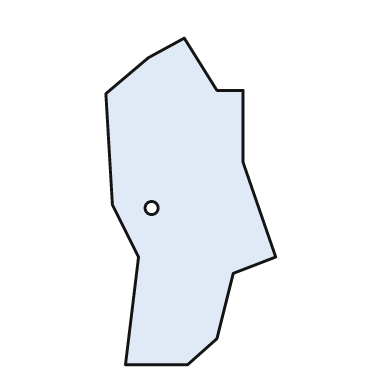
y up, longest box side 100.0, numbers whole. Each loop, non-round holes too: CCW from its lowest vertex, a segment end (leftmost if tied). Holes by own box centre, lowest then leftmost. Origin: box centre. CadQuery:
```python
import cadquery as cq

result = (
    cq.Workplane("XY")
    .moveTo(-20.0, -50.0)
    .lineTo(-1.0, -50.0)
    .lineTo(8.0, -42.0)
    .lineTo(13.0, -22.0)
    .lineTo(26.0, -17.0)
    .lineTo(16.0, 12.0)
    .lineTo(16.0, 34.0)
    .lineTo(8.0, 34.0)
    .lineTo(-2.0, 50.0)
    .lineTo(-13.0, 44.0)
    .lineTo(-26.0, 33.0)
    .lineTo(-24.0, -1.0)
    .lineTo(-16.0, -17.0)
    .close()
    .moveTo(-12.0, -2.0)
    .circle(2.0)
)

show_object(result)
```